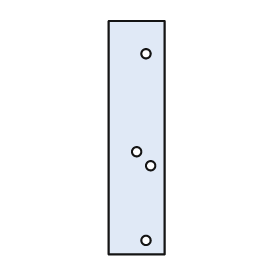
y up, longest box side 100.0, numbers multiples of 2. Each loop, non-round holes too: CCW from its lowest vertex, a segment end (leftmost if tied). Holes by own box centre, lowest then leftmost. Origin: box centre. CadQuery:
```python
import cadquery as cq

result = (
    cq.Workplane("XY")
    .moveTo(-12.0, -50.0)
    .lineTo(12.0, -50.0)
    .lineTo(12.0, 50.0)
    .lineTo(-12.0, 50.0)
    .close()
    .moveTo(4.0, -44.0)
    .circle(2.0)
    .moveTo(6.0, -12.0)
    .circle(2.0)
    .moveTo(0.0, -6.0)
    .circle(2.0)
    .moveTo(4.0, 36.0)
    .circle(2.0)
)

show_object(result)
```